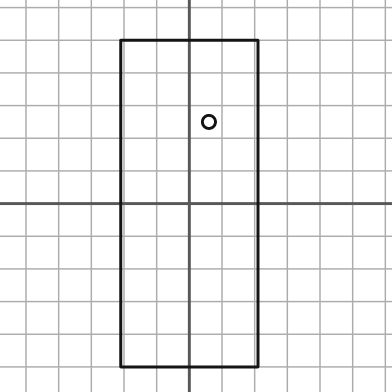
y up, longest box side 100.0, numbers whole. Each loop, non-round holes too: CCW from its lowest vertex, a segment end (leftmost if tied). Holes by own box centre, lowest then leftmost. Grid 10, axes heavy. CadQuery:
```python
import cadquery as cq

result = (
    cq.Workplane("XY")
    .moveTo(-21.0, -50.0)
    .lineTo(21.0, -50.0)
    .lineTo(21.0, 50.0)
    .lineTo(-21.0, 50.0)
    .close()
    .moveTo(6.0, 25.0)
    .circle(2.0)
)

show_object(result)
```